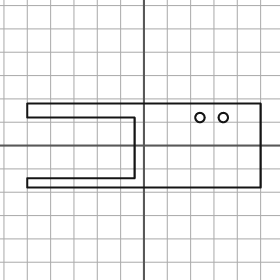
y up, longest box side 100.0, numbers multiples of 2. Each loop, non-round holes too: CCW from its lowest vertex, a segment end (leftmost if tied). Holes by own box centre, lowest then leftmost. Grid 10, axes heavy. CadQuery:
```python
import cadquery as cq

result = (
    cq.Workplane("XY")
    .moveTo(-50.0, -18.0)
    .lineTo(50.0, -18.0)
    .lineTo(50.0, 18.0)
    .lineTo(-50.0, 18.0)
    .lineTo(-50.0, 12.0)
    .lineTo(-4.0, 12.0)
    .lineTo(-4.0, -14.0)
    .lineTo(-50.0, -14.0)
    .close()
    .moveTo(24.0, 12.0)
    .circle(2.0)
    .moveTo(34.0, 12.0)
    .circle(2.0)
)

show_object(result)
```